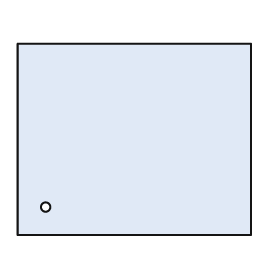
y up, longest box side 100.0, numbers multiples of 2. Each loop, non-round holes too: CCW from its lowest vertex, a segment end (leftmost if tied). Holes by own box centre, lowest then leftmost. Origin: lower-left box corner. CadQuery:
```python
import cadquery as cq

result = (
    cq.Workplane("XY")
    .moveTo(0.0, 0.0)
    .lineTo(100.0, 0.0)
    .lineTo(100.0, 82.0)
    .lineTo(0.0, 82.0)
    .close()
    .moveTo(12.0, 12.0)
    .circle(2.0)
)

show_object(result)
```